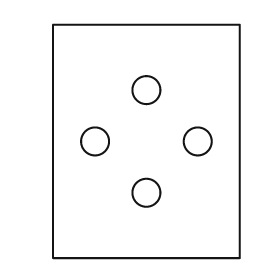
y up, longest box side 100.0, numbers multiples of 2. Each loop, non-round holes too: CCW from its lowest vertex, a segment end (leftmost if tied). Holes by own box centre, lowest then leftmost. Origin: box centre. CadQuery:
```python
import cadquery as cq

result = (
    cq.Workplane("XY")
    .moveTo(-40.0, -50.0)
    .lineTo(40.0, -50.0)
    .lineTo(40.0, 50.0)
    .lineTo(-40.0, 50.0)
    .close()
    .moveTo(0.0, -22.0)
    .circle(6.0)
    .moveTo(-22.0, 0.0)
    .circle(6.0)
    .moveTo(22.0, 0.0)
    .circle(6.0)
    .moveTo(0.0, 22.0)
    .circle(6.0)
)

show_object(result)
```